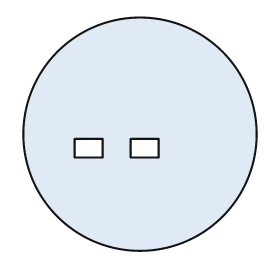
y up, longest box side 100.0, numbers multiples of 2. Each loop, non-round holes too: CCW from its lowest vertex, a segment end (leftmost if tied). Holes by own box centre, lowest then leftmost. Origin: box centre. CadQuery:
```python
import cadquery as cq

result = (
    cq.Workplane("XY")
    .moveTo(0.0, 0.0)
    .circle(50.0)
    .moveTo(-28.0, -10.0)
    .lineTo(-16.0, -10.0)
    .lineTo(-16.0, -2.0)
    .lineTo(-28.0, -2.0)
    .close()
    .moveTo(-4.0, -10.0)
    .lineTo(8.0, -10.0)
    .lineTo(8.0, -2.0)
    .lineTo(-4.0, -2.0)
    .close()
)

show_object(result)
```